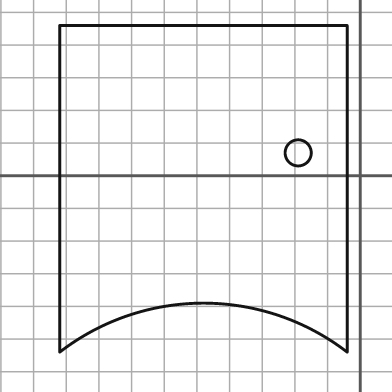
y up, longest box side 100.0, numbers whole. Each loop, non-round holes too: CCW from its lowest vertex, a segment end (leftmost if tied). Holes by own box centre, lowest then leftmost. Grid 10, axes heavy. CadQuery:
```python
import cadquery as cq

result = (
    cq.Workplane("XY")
    .moveTo(-92.0, -54.0)
    .threePointArc((-48.0, -39.0), (-4.0, -54.0))
    .lineTo(-4.0, 46.0)
    .lineTo(-92.0, 46.0)
    .close()
    .moveTo(-19.0, 7.0)
    .circle(4.0)
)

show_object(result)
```